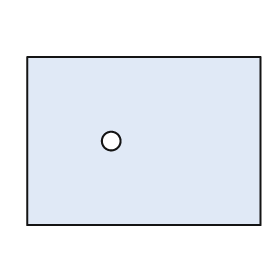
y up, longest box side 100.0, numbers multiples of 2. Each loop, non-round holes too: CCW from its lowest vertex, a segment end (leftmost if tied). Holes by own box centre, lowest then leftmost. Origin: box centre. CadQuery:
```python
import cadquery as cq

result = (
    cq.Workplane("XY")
    .moveTo(-50.0, -36.0)
    .lineTo(50.0, -36.0)
    .lineTo(50.0, 36.0)
    .lineTo(-50.0, 36.0)
    .close()
    .moveTo(-14.0, 0.0)
    .circle(4.0)
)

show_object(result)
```